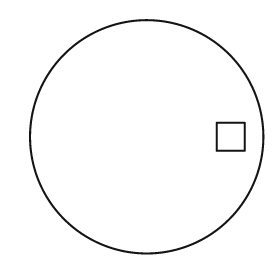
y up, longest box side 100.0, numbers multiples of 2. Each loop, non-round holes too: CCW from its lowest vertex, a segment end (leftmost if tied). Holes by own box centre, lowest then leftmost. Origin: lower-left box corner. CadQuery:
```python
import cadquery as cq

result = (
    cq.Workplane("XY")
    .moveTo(50.0, 50.0)
    .circle(50.0)
    .moveTo(80.0, 44.0)
    .lineTo(92.0, 44.0)
    .lineTo(92.0, 56.0)
    .lineTo(80.0, 56.0)
    .close()
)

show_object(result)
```